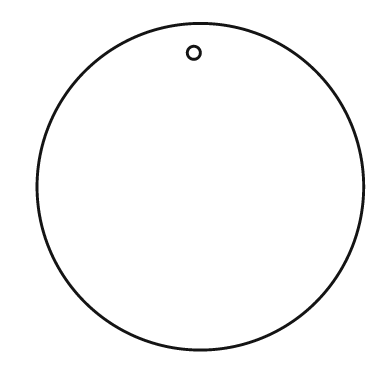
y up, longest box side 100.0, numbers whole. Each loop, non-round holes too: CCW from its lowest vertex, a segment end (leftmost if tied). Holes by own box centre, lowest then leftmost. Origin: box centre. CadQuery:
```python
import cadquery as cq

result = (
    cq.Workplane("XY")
    .moveTo(0.0, 0.0)
    .circle(50.0)
    .moveTo(-2.0, 41.0)
    .circle(2.0)
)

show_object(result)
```